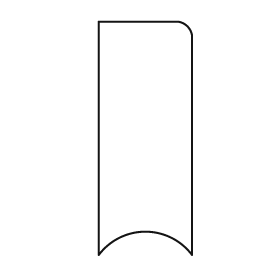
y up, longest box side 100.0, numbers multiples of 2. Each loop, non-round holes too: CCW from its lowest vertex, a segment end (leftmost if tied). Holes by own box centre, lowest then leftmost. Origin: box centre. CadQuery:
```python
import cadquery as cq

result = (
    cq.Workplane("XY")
    .moveTo(-20.0, -50.0)
    .threePointArc((0.0, -40.0), (20.0, -50.0))
    .lineTo(20.0, 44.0)
    .threePointArc((18.0, 48.0), (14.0, 50.0))
    .lineTo(-20.0, 50.0)
    .close()
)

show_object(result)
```